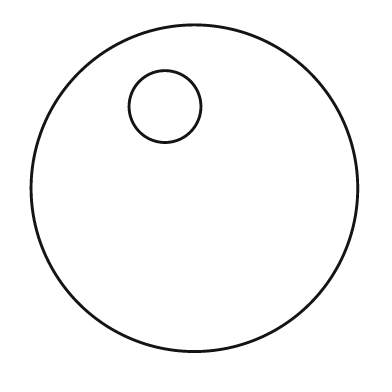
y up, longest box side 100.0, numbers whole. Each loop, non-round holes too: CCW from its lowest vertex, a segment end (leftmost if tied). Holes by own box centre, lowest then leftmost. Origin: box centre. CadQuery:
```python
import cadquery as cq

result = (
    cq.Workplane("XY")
    .moveTo(0.0, 0.0)
    .circle(50.0)
    .moveTo(-9.0, 25.0)
    .circle(11.0)
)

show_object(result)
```